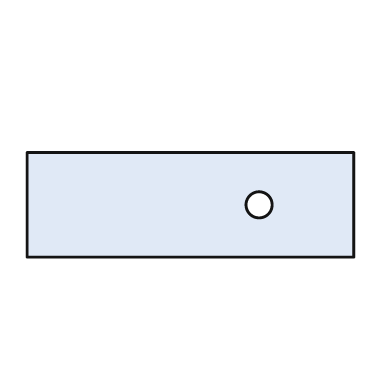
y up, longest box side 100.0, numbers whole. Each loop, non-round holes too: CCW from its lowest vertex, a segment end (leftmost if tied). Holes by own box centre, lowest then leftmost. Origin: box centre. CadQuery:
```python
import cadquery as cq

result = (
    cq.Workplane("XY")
    .moveTo(-50.0, -16.0)
    .lineTo(50.0, -16.0)
    .lineTo(50.0, 16.0)
    .lineTo(-50.0, 16.0)
    .close()
    .moveTo(21.0, 0.0)
    .circle(4.0)
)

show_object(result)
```